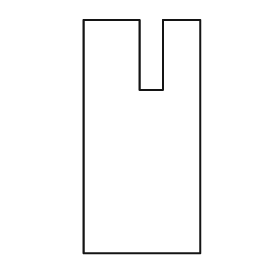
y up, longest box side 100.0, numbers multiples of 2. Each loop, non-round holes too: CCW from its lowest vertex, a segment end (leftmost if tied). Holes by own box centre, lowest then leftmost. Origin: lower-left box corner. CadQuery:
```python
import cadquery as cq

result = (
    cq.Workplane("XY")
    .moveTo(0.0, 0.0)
    .lineTo(50.0, 0.0)
    .lineTo(50.0, 100.0)
    .lineTo(34.0, 100.0)
    .lineTo(34.0, 70.0)
    .lineTo(24.0, 70.0)
    .lineTo(24.0, 100.0)
    .lineTo(0.0, 100.0)
    .close()
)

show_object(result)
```